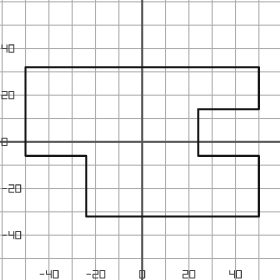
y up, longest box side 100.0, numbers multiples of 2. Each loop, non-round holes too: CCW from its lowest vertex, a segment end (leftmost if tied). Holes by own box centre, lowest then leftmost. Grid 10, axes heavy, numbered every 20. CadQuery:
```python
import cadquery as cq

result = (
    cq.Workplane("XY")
    .moveTo(-24.0, -32.0)
    .lineTo(50.0, -32.0)
    .lineTo(50.0, -6.0)
    .lineTo(24.0, -6.0)
    .lineTo(24.0, 14.0)
    .lineTo(50.0, 14.0)
    .lineTo(50.0, 32.0)
    .lineTo(-50.0, 32.0)
    .lineTo(-50.0, -6.0)
    .lineTo(-24.0, -6.0)
    .close()
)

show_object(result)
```